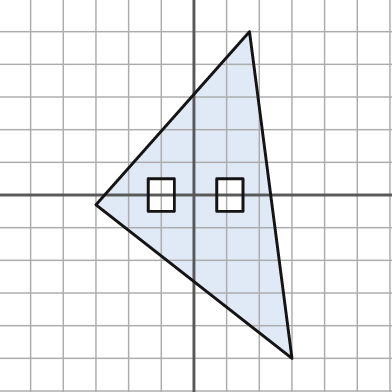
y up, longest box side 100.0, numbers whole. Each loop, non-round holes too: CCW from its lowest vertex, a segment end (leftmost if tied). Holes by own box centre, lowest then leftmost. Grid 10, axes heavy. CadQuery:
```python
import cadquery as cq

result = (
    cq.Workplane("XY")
    .moveTo(30.0, -50.0)
    .lineTo(17.0, 50.0)
    .lineTo(-30.0, -3.0)
    .close()
    .moveTo(-14.0, -5.0)
    .lineTo(-6.0, -5.0)
    .lineTo(-6.0, 5.0)
    .lineTo(-14.0, 5.0)
    .close()
    .moveTo(7.0, -5.0)
    .lineTo(15.0, -5.0)
    .lineTo(15.0, 5.0)
    .lineTo(7.0, 5.0)
    .close()
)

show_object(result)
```